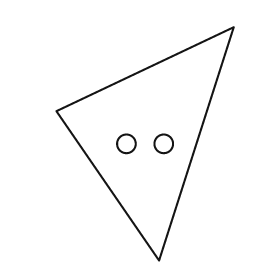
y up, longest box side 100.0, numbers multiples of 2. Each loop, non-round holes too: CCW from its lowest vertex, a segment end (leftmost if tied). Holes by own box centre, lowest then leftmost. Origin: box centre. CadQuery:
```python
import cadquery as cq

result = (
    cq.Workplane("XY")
    .moveTo(6.0, -50.0)
    .lineTo(38.0, 50.0)
    .lineTo(-38.0, 14.0)
    .close()
    .moveTo(-8.0, 0.0)
    .circle(4.0)
    .moveTo(8.0, 0.0)
    .circle(4.0)
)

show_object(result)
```